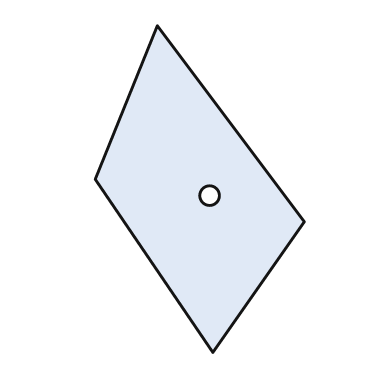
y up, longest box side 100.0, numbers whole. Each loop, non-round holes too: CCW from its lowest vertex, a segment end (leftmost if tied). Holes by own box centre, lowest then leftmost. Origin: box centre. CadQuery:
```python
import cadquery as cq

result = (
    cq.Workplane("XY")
    .moveTo(4.0, -50.0)
    .lineTo(32.0, -10.0)
    .lineTo(-13.0, 50.0)
    .lineTo(-32.0, 3.0)
    .close()
    .moveTo(3.0, -2.0)
    .circle(3.0)
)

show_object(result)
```